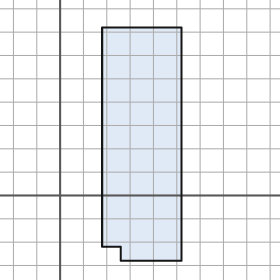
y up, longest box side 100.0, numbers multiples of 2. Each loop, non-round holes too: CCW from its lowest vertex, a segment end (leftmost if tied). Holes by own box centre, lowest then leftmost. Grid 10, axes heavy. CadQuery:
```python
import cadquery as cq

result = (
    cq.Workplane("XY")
    .moveTo(26.0, -28.0)
    .lineTo(52.0, -28.0)
    .lineTo(52.0, 72.0)
    .lineTo(18.0, 72.0)
    .lineTo(18.0, -22.0)
    .lineTo(26.0, -22.0)
    .close()
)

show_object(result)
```